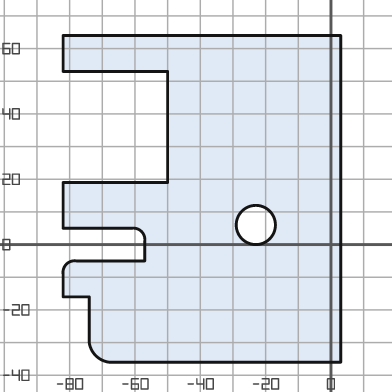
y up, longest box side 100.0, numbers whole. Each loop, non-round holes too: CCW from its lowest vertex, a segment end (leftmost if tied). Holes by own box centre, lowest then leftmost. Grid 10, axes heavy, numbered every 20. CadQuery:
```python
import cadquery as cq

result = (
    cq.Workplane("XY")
    .moveTo(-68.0, -36.0)
    .lineTo(3.0, -36.0)
    .lineTo(3.0, 64.0)
    .lineTo(-82.0, 64.0)
    .lineTo(-82.0, 53.0)
    .lineTo(-50.0, 53.0)
    .lineTo(-50.0, 19.0)
    .lineTo(-82.0, 19.0)
    .lineTo(-82.0, 5.0)
    .lineTo(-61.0, 5.0)
    .threePointArc((-58.0, 4.0), (-57.0, 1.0))
    .lineTo(-57.0, -5.0)
    .lineTo(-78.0, -5.0)
    .threePointArc((-81.0, -6.0), (-82.0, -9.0))
    .lineTo(-82.0, -16.0)
    .lineTo(-74.0, -16.0)
    .lineTo(-74.0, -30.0)
    .threePointArc((-72.0, -34.0), (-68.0, -36.0))
    .close()
    .moveTo(-23.0, 6.0)
    .circle(6.0)
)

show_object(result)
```